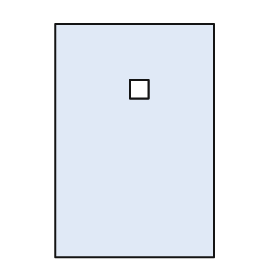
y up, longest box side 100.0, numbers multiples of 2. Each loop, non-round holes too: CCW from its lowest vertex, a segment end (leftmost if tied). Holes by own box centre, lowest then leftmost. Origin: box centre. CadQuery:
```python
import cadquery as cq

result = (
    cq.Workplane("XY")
    .moveTo(-34.0, -50.0)
    .lineTo(34.0, -50.0)
    .lineTo(34.0, 50.0)
    .lineTo(-34.0, 50.0)
    .close()
    .moveTo(-2.0, 18.0)
    .lineTo(6.0, 18.0)
    .lineTo(6.0, 26.0)
    .lineTo(-2.0, 26.0)
    .close()
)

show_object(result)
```